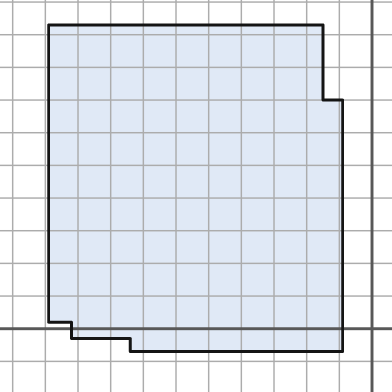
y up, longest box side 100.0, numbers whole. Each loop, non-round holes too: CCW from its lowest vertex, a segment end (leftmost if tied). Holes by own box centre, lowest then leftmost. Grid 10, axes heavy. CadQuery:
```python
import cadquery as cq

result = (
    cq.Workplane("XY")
    .moveTo(-74.0, -7.0)
    .lineTo(-9.0, -7.0)
    .lineTo(-9.0, 70.0)
    .lineTo(-15.0, 70.0)
    .lineTo(-15.0, 93.0)
    .lineTo(-99.0, 93.0)
    .lineTo(-99.0, 2.0)
    .lineTo(-92.0, 2.0)
    .lineTo(-92.0, -3.0)
    .lineTo(-74.0, -3.0)
    .close()
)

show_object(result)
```